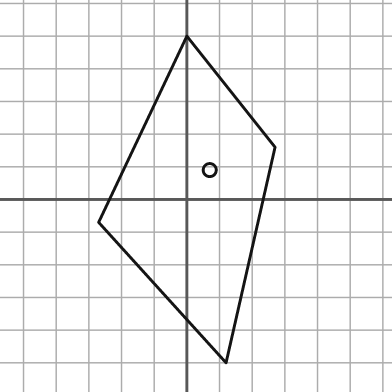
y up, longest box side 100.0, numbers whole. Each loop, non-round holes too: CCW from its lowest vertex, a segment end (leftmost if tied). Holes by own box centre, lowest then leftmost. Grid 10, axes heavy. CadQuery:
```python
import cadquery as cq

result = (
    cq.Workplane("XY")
    .moveTo(12.0, -50.0)
    .lineTo(27.0, 16.0)
    .lineTo(0.0, 50.0)
    .lineTo(-27.0, -7.0)
    .close()
    .moveTo(7.0, 9.0)
    .circle(2.0)
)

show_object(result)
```